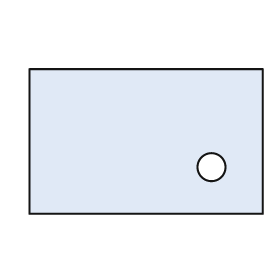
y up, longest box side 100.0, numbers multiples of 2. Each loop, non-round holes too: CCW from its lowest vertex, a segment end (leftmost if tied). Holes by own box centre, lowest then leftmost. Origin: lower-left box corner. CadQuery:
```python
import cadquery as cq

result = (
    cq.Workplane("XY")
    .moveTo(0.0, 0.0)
    .lineTo(100.0, 0.0)
    .lineTo(100.0, 62.0)
    .lineTo(0.0, 62.0)
    .close()
    .moveTo(78.0, 20.0)
    .circle(6.0)
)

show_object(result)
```